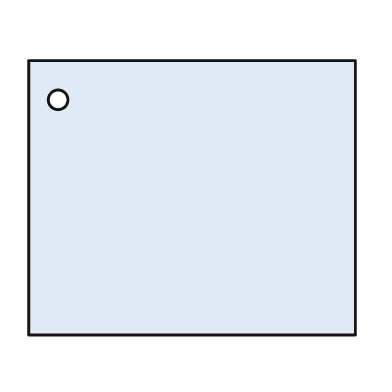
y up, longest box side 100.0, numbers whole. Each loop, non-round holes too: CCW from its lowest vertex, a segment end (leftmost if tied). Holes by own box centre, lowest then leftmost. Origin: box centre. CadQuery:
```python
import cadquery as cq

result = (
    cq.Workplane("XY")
    .moveTo(-50.0, -42.0)
    .lineTo(50.0, -42.0)
    .lineTo(50.0, 42.0)
    .lineTo(-50.0, 42.0)
    .close()
    .moveTo(-41.0, 30.0)
    .circle(3.0)
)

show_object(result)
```